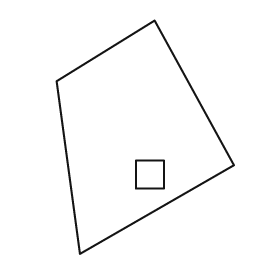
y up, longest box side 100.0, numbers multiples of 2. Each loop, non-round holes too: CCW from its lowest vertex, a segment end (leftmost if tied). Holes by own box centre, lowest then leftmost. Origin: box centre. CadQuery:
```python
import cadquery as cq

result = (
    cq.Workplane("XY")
    .moveTo(-28.0, -50.0)
    .lineTo(38.0, -12.0)
    .lineTo(4.0, 50.0)
    .lineTo(-38.0, 24.0)
    .close()
    .moveTo(-4.0, -22.0)
    .lineTo(8.0, -22.0)
    .lineTo(8.0, -10.0)
    .lineTo(-4.0, -10.0)
    .close()
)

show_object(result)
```